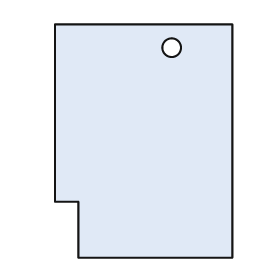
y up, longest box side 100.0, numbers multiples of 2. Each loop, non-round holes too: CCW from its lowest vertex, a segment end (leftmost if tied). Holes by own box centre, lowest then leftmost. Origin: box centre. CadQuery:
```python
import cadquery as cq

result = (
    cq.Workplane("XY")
    .moveTo(-28.0, -50.0)
    .lineTo(38.0, -50.0)
    .lineTo(38.0, 50.0)
    .lineTo(-38.0, 50.0)
    .lineTo(-38.0, -26.0)
    .lineTo(-28.0, -26.0)
    .close()
    .moveTo(12.0, 40.0)
    .circle(4.0)
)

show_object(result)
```